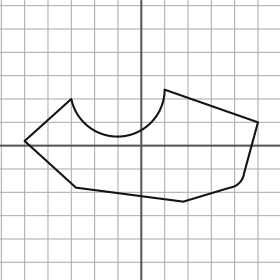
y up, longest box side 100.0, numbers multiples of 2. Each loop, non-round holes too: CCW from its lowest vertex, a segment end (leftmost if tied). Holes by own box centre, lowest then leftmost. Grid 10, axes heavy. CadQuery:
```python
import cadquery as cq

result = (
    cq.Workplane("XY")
    .moveTo(18.0, -24.0)
    .lineTo(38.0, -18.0)
    .threePointArc((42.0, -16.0), (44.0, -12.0))
    .lineTo(50.0, 10.0)
    .lineTo(10.0, 24.0)
    .threePointArc((-8.0, 4.0), (-30.0, 20.0))
    .lineTo(-50.0, 2.0)
    .lineTo(-28.0, -18.0)
    .close()
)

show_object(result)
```